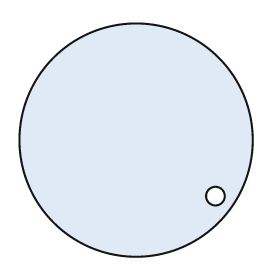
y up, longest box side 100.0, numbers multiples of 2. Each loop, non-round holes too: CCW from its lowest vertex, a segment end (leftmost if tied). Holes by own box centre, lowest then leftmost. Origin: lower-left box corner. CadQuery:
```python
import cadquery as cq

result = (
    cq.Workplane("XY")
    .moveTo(50.0, 50.0)
    .circle(50.0)
    .moveTo(84.0, 26.0)
    .circle(4.0)
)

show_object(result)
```